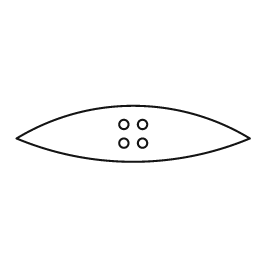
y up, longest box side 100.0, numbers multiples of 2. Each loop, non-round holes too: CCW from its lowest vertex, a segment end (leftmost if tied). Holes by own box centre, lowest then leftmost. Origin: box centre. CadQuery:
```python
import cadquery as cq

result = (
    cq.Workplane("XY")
    .moveTo(-50.0, -2.0)
    .threePointArc((0.0, -12.0), (50.0, -2.0))
    .threePointArc((0.0, 12.0), (-50.0, -2.0))
    .close()
    .moveTo(-4.0, -4.0)
    .circle(2.0)
    .moveTo(4.0, -4.0)
    .circle(2.0)
    .moveTo(-4.0, 4.0)
    .circle(2.0)
    .moveTo(4.0, 4.0)
    .circle(2.0)
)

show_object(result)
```